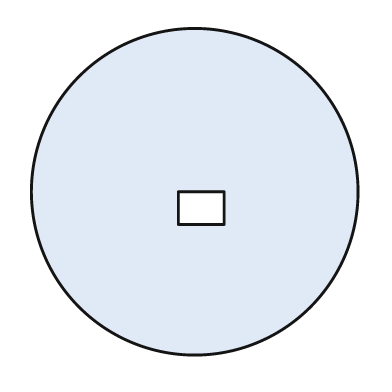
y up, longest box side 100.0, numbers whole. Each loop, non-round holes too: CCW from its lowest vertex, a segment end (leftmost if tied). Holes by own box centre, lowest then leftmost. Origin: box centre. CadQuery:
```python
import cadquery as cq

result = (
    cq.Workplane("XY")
    .moveTo(0.0, 0.0)
    .circle(50.0)
    .moveTo(-5.0, -10.0)
    .lineTo(9.0, -10.0)
    .lineTo(9.0, 0.0)
    .lineTo(-5.0, 0.0)
    .close()
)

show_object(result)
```